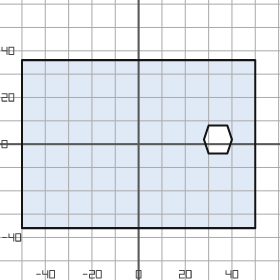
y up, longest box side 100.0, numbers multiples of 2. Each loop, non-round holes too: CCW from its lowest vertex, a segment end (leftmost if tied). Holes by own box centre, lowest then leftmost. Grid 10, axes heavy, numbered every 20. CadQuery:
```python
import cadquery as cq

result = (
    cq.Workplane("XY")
    .moveTo(-50.0, -36.0)
    .lineTo(50.0, -36.0)
    .lineTo(50.0, 36.0)
    .lineTo(-50.0, 36.0)
    .close()
    .moveTo(30.0, -4.0)
    .lineTo(38.0, -4.0)
    .lineTo(40.0, 2.0)
    .lineTo(38.0, 8.0)
    .lineTo(30.0, 8.0)
    .lineTo(28.0, 2.0)
    .close()
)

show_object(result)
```